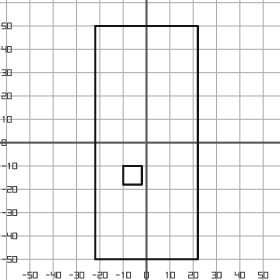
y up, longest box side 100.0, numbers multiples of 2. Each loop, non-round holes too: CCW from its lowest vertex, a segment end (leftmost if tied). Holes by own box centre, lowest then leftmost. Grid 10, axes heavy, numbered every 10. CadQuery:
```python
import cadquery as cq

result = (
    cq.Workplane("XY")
    .moveTo(-22.0, -50.0)
    .lineTo(22.0, -50.0)
    .lineTo(22.0, 50.0)
    .lineTo(-22.0, 50.0)
    .close()
    .moveTo(-10.0, -18.0)
    .lineTo(-2.0, -18.0)
    .lineTo(-2.0, -10.0)
    .lineTo(-10.0, -10.0)
    .close()
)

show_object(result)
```